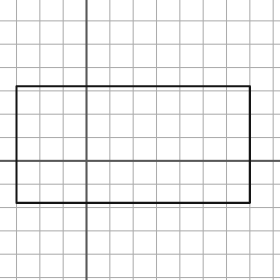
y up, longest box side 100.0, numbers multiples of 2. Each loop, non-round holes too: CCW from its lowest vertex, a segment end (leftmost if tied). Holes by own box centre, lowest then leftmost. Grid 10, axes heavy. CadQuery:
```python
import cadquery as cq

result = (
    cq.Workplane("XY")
    .moveTo(-30.0, -18.0)
    .lineTo(70.0, -18.0)
    .lineTo(70.0, 32.0)
    .lineTo(-30.0, 32.0)
    .close()
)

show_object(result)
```